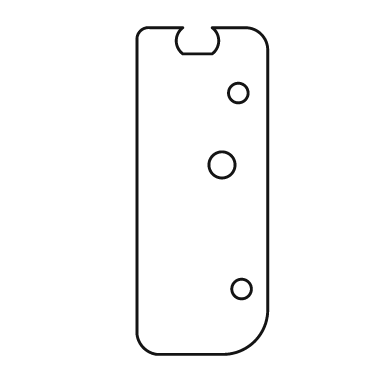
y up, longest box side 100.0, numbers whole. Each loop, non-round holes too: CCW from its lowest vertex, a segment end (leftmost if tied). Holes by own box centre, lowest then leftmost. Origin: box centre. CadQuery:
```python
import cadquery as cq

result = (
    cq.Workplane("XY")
    .moveTo(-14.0, -50.0)
    .lineTo(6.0, -50.0)
    .threePointArc((16.0, -46.0), (20.0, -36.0))
    .lineTo(20.0, 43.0)
    .threePointArc((18.0, 48.0), (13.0, 50.0))
    .lineTo(3.0, 50.0)
    .threePointArc((5.0, 46.0), (3.0, 42.0))
    .lineTo(-6.0, 42.0)
    .threePointArc((-8.0, 46.0), (-6.0, 50.0))
    .lineTo(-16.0, 50.0)
    .threePointArc((-19.0, 49.0), (-20.0, 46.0))
    .lineTo(-20.0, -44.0)
    .threePointArc((-18.0, -48.0), (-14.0, -50.0))
    .close()
    .moveTo(12.0, -30.0)
    .circle(3.0)
    .moveTo(6.0, 8.0)
    .circle(4.0)
    .moveTo(11.0, 30.0)
    .circle(3.0)
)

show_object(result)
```